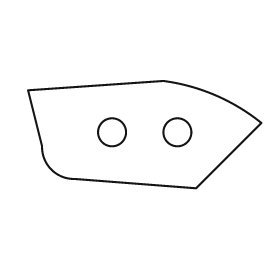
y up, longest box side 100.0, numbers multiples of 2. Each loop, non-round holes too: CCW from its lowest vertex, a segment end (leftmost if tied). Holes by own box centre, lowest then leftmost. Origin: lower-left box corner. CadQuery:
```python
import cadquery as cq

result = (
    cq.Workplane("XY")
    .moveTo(72.0, 0.0)
    .lineTo(100.0, 28.0)
    .threePointArc((80.0, 40.0), (58.0, 46.0))
    .lineTo(0.0, 42.0)
    .lineTo(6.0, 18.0)
    .threePointArc((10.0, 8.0), (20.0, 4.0))
    .close()
    .moveTo(36.0, 24.0)
    .circle(6.0)
    .moveTo(64.0, 24.0)
    .circle(6.0)
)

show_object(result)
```